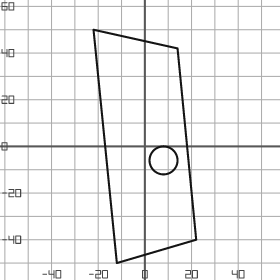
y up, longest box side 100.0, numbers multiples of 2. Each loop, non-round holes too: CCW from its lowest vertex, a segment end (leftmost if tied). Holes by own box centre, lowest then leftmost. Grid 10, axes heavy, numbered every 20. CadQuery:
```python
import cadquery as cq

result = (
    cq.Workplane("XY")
    .moveTo(-12.0, -50.0)
    .lineTo(22.0, -40.0)
    .lineTo(14.0, 42.0)
    .lineTo(-22.0, 50.0)
    .close()
    .moveTo(8.0, -6.0)
    .circle(6.0)
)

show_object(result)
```